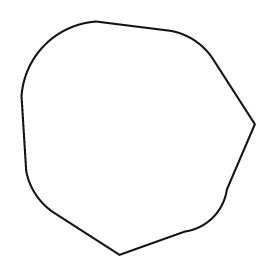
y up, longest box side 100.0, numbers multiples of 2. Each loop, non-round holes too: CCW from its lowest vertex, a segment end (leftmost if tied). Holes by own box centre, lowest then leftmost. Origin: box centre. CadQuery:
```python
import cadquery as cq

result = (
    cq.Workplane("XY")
    .moveTo(-8.0, -50.0)
    .lineTo(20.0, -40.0)
    .threePointArc((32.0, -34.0), (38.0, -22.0))
    .lineTo(50.0, 6.0)
    .lineTo(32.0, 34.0)
    .threePointArc((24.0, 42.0), (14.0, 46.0))
    .lineTo(-18.0, 50.0)
    .threePointArc((-40.0, 40.0), (-50.0, 18.0))
    .lineTo(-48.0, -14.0)
    .threePointArc((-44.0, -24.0), (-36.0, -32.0))
    .close()
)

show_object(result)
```